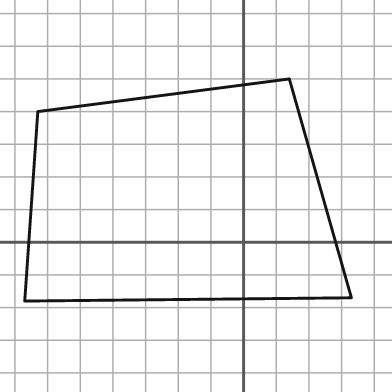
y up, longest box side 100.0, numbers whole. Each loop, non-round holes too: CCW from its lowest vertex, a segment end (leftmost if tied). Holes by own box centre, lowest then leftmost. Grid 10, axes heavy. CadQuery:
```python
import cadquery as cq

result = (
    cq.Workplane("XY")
    .moveTo(-67.0, -18.0)
    .lineTo(33.0, -17.0)
    .lineTo(14.0, 50.0)
    .lineTo(-63.0, 40.0)
    .close()
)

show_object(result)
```